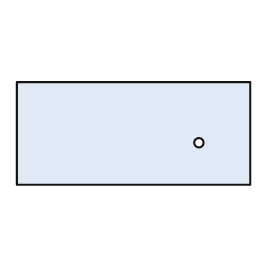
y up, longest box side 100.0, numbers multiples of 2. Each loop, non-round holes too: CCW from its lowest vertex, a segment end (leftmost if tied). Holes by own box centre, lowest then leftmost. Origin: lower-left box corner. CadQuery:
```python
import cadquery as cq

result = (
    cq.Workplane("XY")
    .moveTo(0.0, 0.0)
    .lineTo(100.0, 0.0)
    .lineTo(100.0, 44.0)
    .lineTo(0.0, 44.0)
    .close()
    .moveTo(78.0, 18.0)
    .circle(2.0)
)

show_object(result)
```